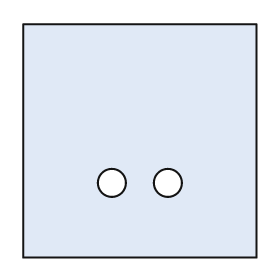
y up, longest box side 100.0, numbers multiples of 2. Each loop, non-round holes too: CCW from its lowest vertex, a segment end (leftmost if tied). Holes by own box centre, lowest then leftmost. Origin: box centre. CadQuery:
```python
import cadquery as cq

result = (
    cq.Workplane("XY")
    .moveTo(-50.0, -50.0)
    .lineTo(50.0, -50.0)
    .lineTo(50.0, 50.0)
    .lineTo(-50.0, 50.0)
    .close()
    .moveTo(-12.0, -18.0)
    .circle(6.0)
    .moveTo(12.0, -18.0)
    .circle(6.0)
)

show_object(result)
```